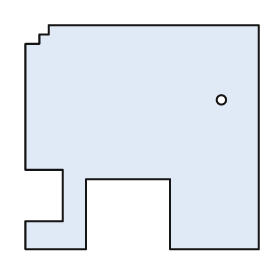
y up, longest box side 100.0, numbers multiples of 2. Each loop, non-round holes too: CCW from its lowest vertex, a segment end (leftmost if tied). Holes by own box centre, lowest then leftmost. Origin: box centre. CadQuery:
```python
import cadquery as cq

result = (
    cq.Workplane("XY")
    .moveTo(-50.0, -48.0)
    .lineTo(-24.0, -48.0)
    .lineTo(-24.0, -18.0)
    .lineTo(12.0, -18.0)
    .lineTo(12.0, -48.0)
    .lineTo(50.0, -48.0)
    .lineTo(50.0, 48.0)
    .lineTo(-40.0, 48.0)
    .lineTo(-40.0, 44.0)
    .lineTo(-44.0, 44.0)
    .lineTo(-44.0, 40.0)
    .lineTo(-50.0, 40.0)
    .lineTo(-50.0, -14.0)
    .lineTo(-34.0, -14.0)
    .lineTo(-34.0, -36.0)
    .lineTo(-50.0, -36.0)
    .close()
    .moveTo(34.0, 16.0)
    .circle(2.0)
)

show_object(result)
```